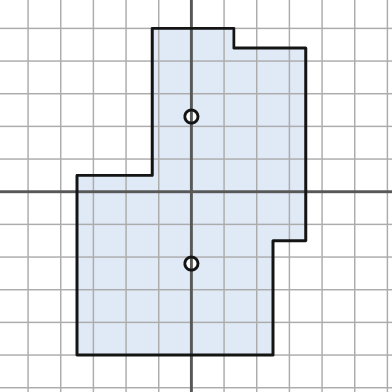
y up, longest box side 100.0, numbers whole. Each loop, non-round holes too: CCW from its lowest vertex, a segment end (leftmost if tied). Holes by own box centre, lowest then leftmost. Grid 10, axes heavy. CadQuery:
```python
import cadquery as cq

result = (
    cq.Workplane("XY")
    .moveTo(-35.0, -50.0)
    .lineTo(25.0, -50.0)
    .lineTo(25.0, -15.0)
    .lineTo(35.0, -15.0)
    .lineTo(35.0, 44.0)
    .lineTo(13.0, 44.0)
    .lineTo(13.0, 50.0)
    .lineTo(-12.0, 50.0)
    .lineTo(-12.0, 5.0)
    .lineTo(-35.0, 5.0)
    .close()
    .moveTo(0.0, -22.0)
    .circle(2.0)
    .moveTo(0.0, 23.0)
    .circle(2.0)
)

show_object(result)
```